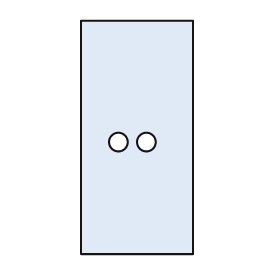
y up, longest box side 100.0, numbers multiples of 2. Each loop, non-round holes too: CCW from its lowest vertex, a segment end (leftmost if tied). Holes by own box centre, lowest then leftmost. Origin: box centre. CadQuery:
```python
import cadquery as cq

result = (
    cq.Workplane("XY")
    .moveTo(-24.0, -50.0)
    .lineTo(24.0, -50.0)
    .lineTo(24.0, 50.0)
    .lineTo(-24.0, 50.0)
    .close()
    .moveTo(-8.0, -2.0)
    .circle(4.0)
    .moveTo(4.0, -2.0)
    .circle(4.0)
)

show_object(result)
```